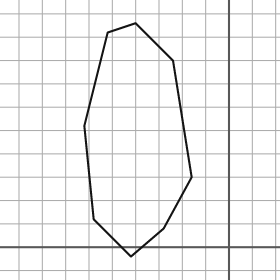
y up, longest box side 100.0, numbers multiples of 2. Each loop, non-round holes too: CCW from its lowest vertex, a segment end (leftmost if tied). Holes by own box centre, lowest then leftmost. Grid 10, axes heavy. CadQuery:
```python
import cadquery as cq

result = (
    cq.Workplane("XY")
    .moveTo(-42.0, -4.0)
    .lineTo(-28.0, 8.0)
    .lineTo(-16.0, 30.0)
    .lineTo(-24.0, 80.0)
    .lineTo(-40.0, 96.0)
    .lineTo(-52.0, 92.0)
    .lineTo(-62.0, 52.0)
    .lineTo(-58.0, 12.0)
    .close()
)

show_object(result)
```